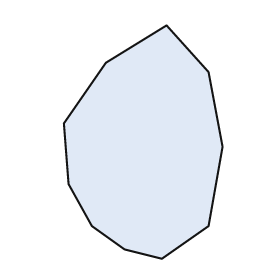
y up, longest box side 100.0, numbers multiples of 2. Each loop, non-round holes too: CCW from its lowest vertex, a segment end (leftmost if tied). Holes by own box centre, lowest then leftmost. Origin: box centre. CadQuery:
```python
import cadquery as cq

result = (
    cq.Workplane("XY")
    .moveTo(8.0, -50.0)
    .lineTo(28.0, -36.0)
    .lineTo(34.0, -2.0)
    .lineTo(28.0, 30.0)
    .lineTo(10.0, 50.0)
    .lineTo(-16.0, 34.0)
    .lineTo(-34.0, 8.0)
    .lineTo(-32.0, -18.0)
    .lineTo(-22.0, -36.0)
    .lineTo(-8.0, -46.0)
    .close()
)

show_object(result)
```